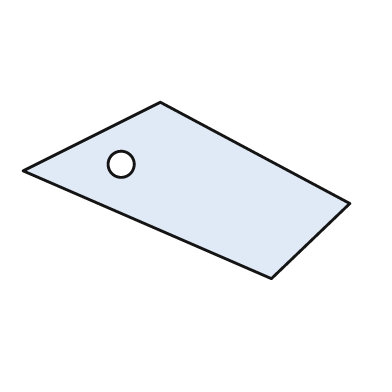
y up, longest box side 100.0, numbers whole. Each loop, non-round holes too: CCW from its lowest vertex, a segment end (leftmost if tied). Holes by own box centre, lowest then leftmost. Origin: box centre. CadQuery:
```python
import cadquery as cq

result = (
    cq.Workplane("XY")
    .moveTo(26.0, -27.0)
    .lineTo(50.0, -4.0)
    .lineTo(-8.0, 27.0)
    .lineTo(-50.0, 6.0)
    .close()
    .moveTo(-20.0, 8.0)
    .circle(4.0)
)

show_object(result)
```